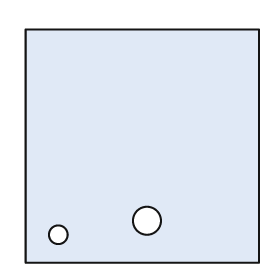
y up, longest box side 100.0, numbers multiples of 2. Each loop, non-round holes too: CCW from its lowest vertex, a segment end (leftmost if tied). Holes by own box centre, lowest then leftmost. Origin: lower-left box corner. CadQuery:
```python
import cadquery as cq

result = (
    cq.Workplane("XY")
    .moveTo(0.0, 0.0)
    .lineTo(100.0, 0.0)
    .lineTo(100.0, 100.0)
    .lineTo(0.0, 100.0)
    .close()
    .moveTo(14.0, 12.0)
    .circle(4.0)
    .moveTo(52.0, 18.0)
    .circle(6.0)
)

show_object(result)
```